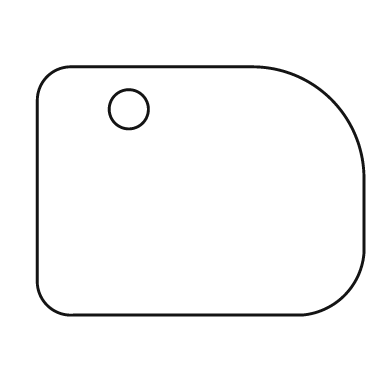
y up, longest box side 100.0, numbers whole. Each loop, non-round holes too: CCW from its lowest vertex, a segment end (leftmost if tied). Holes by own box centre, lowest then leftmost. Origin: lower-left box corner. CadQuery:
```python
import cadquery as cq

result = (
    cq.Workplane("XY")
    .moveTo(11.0, 0.0)
    .lineTo(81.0, 0.0)
    .threePointArc((94.0, 6.0), (100.0, 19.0))
    .lineTo(100.0, 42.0)
    .threePointArc((90.0, 66.0), (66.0, 76.0))
    .lineTo(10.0, 76.0)
    .threePointArc((3.0, 73.0), (0.0, 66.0))
    .lineTo(0.0, 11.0)
    .threePointArc((3.0, 3.0), (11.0, 0.0))
    .close()
    .moveTo(28.0, 63.0)
    .circle(6.0)
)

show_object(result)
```